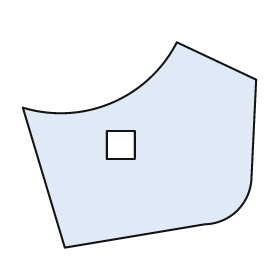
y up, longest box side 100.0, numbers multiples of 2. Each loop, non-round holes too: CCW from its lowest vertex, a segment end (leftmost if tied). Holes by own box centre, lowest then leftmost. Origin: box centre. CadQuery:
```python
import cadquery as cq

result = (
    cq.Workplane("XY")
    .moveTo(-32.0, -44.0)
    .lineTo(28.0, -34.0)
    .threePointArc((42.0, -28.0), (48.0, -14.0))
    .lineTo(50.0, 28.0)
    .lineTo(16.0, 44.0)
    .threePointArc((-12.0, 18.0), (-50.0, 16.0))
    .close()
    .moveTo(-14.0, -6.0)
    .lineTo(-2.0, -6.0)
    .lineTo(-2.0, 6.0)
    .lineTo(-14.0, 6.0)
    .close()
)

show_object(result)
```